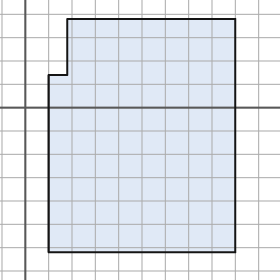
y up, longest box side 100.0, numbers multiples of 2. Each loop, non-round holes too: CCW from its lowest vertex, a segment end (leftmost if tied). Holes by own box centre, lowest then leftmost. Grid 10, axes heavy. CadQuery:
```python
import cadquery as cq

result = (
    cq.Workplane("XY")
    .moveTo(10.0, -62.0)
    .lineTo(90.0, -62.0)
    .lineTo(90.0, 38.0)
    .lineTo(18.0, 38.0)
    .lineTo(18.0, 14.0)
    .lineTo(10.0, 14.0)
    .close()
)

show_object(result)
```